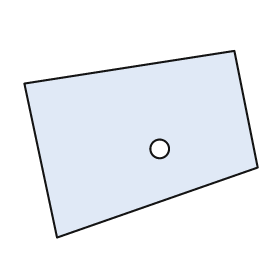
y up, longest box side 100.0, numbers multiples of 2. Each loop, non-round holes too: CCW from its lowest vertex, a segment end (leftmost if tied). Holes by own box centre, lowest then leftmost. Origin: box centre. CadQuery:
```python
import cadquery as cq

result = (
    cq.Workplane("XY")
    .moveTo(-36.0, -40.0)
    .lineTo(50.0, -10.0)
    .lineTo(40.0, 40.0)
    .lineTo(-50.0, 26.0)
    .close()
    .moveTo(8.0, -2.0)
    .circle(4.0)
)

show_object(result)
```